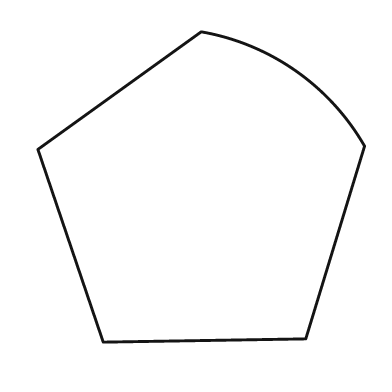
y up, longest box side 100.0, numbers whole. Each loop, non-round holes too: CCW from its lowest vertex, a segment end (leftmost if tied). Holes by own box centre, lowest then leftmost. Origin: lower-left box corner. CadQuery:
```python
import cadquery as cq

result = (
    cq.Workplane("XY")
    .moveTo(20.0, 0.0)
    .lineTo(82.0, 1.0)
    .lineTo(100.0, 60.0)
    .threePointArc((79.0, 83.0), (50.0, 95.0))
    .lineTo(0.0, 59.0)
    .close()
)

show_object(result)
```